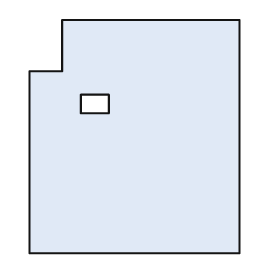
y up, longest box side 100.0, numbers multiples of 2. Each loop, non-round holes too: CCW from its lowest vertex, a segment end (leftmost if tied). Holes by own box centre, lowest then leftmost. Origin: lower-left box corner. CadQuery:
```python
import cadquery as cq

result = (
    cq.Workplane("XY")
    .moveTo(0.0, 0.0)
    .lineTo(90.0, 0.0)
    .lineTo(90.0, 100.0)
    .lineTo(14.0, 100.0)
    .lineTo(14.0, 78.0)
    .lineTo(0.0, 78.0)
    .close()
    .moveTo(22.0, 60.0)
    .lineTo(34.0, 60.0)
    .lineTo(34.0, 68.0)
    .lineTo(22.0, 68.0)
    .close()
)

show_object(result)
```